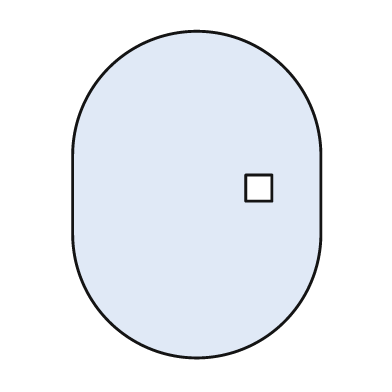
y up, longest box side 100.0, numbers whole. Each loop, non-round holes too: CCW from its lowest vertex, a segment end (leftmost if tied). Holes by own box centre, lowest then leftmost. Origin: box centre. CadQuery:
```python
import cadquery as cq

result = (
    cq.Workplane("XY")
    .moveTo(-38.0, -12.0)
    .threePointArc((0.0, -50.0), (38.0, -12.0))
    .lineTo(38.0, 12.0)
    .threePointArc((0.0, 50.0), (-38.0, 12.0))
    .close()
    .moveTo(15.0, -2.0)
    .lineTo(23.0, -2.0)
    .lineTo(23.0, 6.0)
    .lineTo(15.0, 6.0)
    .close()
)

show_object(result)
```